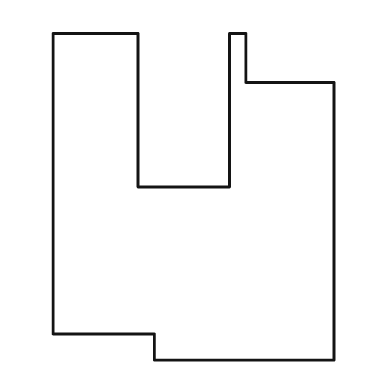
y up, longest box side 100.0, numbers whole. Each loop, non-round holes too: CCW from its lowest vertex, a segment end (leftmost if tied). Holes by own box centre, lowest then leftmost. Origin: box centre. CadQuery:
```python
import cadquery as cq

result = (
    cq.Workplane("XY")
    .moveTo(-12.0, -50.0)
    .lineTo(43.0, -50.0)
    .lineTo(43.0, 35.0)
    .lineTo(16.0, 35.0)
    .lineTo(16.0, 50.0)
    .lineTo(11.0, 50.0)
    .lineTo(11.0, 3.0)
    .lineTo(-17.0, 3.0)
    .lineTo(-17.0, 50.0)
    .lineTo(-43.0, 50.0)
    .lineTo(-43.0, -42.0)
    .lineTo(-12.0, -42.0)
    .close()
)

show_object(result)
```